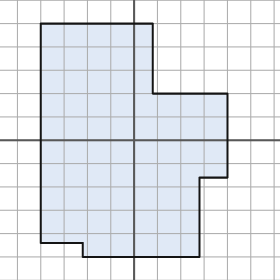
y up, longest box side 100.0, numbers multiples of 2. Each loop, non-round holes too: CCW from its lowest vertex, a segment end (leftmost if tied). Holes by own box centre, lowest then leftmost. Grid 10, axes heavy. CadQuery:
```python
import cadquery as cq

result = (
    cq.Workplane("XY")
    .moveTo(-22.0, -50.0)
    .lineTo(28.0, -50.0)
    .lineTo(28.0, -16.0)
    .lineTo(40.0, -16.0)
    .lineTo(40.0, 20.0)
    .lineTo(8.0, 20.0)
    .lineTo(8.0, 50.0)
    .lineTo(-40.0, 50.0)
    .lineTo(-40.0, -44.0)
    .lineTo(-22.0, -44.0)
    .close()
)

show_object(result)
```